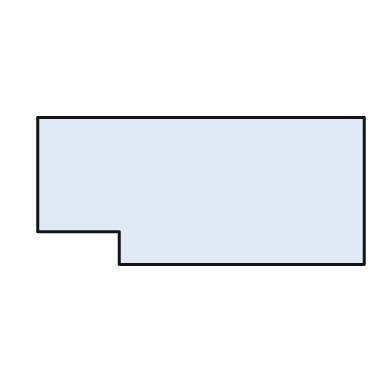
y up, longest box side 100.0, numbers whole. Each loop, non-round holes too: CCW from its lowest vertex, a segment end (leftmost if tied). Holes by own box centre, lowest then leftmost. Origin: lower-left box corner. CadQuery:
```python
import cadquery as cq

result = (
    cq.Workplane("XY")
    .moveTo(25.0, 0.0)
    .lineTo(100.0, 0.0)
    .lineTo(100.0, 45.0)
    .lineTo(0.0, 45.0)
    .lineTo(0.0, 10.0)
    .lineTo(25.0, 10.0)
    .close()
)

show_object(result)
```